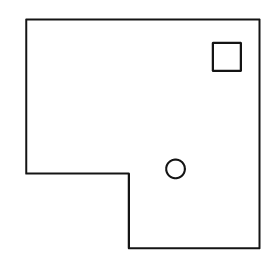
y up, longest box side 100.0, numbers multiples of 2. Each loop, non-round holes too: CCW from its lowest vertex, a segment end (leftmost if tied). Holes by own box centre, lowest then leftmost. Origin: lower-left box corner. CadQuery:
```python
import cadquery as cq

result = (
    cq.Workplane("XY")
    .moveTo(44.0, 0.0)
    .lineTo(100.0, 0.0)
    .lineTo(100.0, 98.0)
    .lineTo(0.0, 98.0)
    .lineTo(0.0, 32.0)
    .lineTo(44.0, 32.0)
    .close()
    .moveTo(64.0, 34.0)
    .circle(4.0)
    .moveTo(80.0, 76.0)
    .lineTo(92.0, 76.0)
    .lineTo(92.0, 88.0)
    .lineTo(80.0, 88.0)
    .close()
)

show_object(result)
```